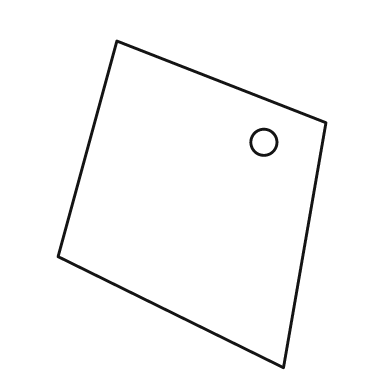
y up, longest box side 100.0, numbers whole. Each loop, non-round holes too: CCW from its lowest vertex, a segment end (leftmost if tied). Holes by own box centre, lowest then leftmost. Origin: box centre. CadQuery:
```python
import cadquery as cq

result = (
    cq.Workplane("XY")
    .moveTo(28.0, -50.0)
    .lineTo(41.0, 25.0)
    .lineTo(-23.0, 50.0)
    .lineTo(-41.0, -16.0)
    .close()
    .moveTo(22.0, 19.0)
    .circle(4.0)
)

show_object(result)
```